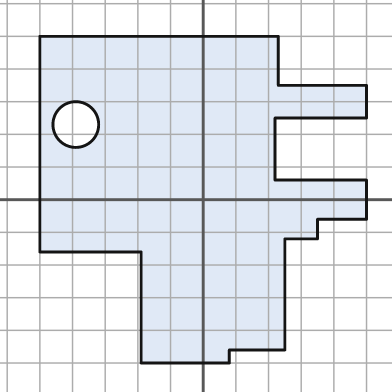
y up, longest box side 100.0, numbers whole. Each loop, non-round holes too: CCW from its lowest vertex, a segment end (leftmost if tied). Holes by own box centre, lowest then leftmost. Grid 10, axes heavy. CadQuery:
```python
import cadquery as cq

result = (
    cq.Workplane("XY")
    .moveTo(-19.0, -50.0)
    .lineTo(8.0, -50.0)
    .lineTo(8.0, -46.0)
    .lineTo(25.0, -46.0)
    .lineTo(25.0, -12.0)
    .lineTo(35.0, -12.0)
    .lineTo(35.0, -6.0)
    .lineTo(50.0, -6.0)
    .lineTo(50.0, 6.0)
    .lineTo(22.0, 6.0)
    .lineTo(22.0, 25.0)
    .lineTo(50.0, 25.0)
    .lineTo(50.0, 35.0)
    .lineTo(23.0, 35.0)
    .lineTo(23.0, 50.0)
    .lineTo(-50.0, 50.0)
    .lineTo(-50.0, -16.0)
    .lineTo(-19.0, -16.0)
    .close()
    .moveTo(-39.0, 23.0)
    .circle(7.0)
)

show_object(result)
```